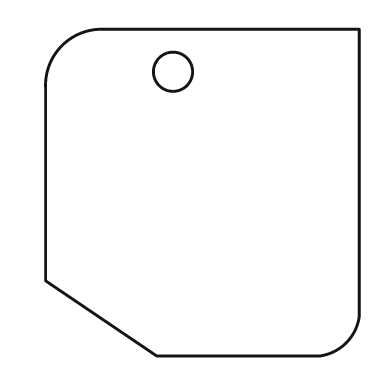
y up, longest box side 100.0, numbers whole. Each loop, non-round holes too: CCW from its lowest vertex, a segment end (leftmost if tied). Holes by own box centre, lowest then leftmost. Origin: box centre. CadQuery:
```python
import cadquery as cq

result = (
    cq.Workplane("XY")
    .moveTo(-14.0, -50.0)
    .lineTo(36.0, -50.0)
    .threePointArc((44.0, -46.0), (48.0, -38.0))
    .lineTo(48.0, 50.0)
    .lineTo(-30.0, 50.0)
    .threePointArc((-43.0, 45.0), (-48.0, 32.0))
    .lineTo(-48.0, -27.0)
    .close()
    .moveTo(-9.0, 37.0)
    .circle(6.0)
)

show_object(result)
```